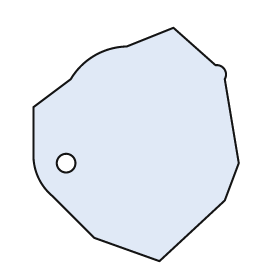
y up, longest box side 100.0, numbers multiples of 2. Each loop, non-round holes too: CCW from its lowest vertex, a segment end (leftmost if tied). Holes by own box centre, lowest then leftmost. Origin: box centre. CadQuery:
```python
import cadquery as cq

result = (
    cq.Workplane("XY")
    .moveTo(10.0, -50.0)
    .lineTo(38.0, -24.0)
    .lineTo(44.0, -8.0)
    .lineTo(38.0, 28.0)
    .threePointArc((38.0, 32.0), (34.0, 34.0))
    .lineTo(16.0, 50.0)
    .lineTo(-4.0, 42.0)
    .threePointArc((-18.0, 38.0), (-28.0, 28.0))
    .lineTo(-44.0, 16.0)
    .lineTo(-44.0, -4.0)
    .threePointArc((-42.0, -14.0), (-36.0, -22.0))
    .lineTo(-18.0, -40.0)
    .close()
    .moveTo(-30.0, -8.0)
    .circle(4.0)
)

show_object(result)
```